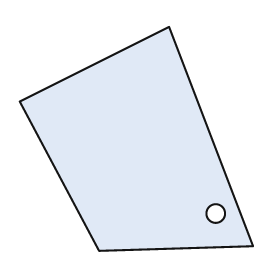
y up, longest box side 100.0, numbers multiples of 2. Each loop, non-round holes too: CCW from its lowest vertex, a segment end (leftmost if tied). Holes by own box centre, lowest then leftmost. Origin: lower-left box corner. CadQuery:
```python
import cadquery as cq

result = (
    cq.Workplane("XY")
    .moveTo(34.0, 0.0)
    .lineTo(100.0, 2.0)
    .lineTo(64.0, 96.0)
    .lineTo(0.0, 64.0)
    .close()
    .moveTo(84.0, 16.0)
    .circle(4.0)
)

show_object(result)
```